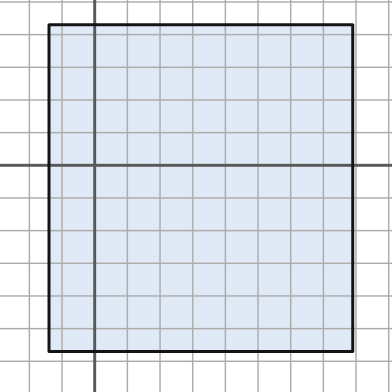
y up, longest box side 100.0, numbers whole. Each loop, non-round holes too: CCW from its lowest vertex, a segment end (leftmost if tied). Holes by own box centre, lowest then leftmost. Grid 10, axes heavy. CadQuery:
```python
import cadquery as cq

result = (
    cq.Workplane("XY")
    .moveTo(-14.0, -57.0)
    .lineTo(79.0, -57.0)
    .lineTo(79.0, 43.0)
    .lineTo(-14.0, 43.0)
    .close()
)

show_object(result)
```